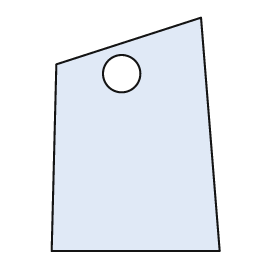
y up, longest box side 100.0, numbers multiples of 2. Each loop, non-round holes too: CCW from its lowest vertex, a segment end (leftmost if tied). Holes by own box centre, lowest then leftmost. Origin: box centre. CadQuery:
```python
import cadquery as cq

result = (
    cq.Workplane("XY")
    .moveTo(-36.0, -50.0)
    .lineTo(36.0, -50.0)
    .lineTo(28.0, 50.0)
    .lineTo(-34.0, 30.0)
    .close()
    .moveTo(-6.0, 26.0)
    .circle(8.0)
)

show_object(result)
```